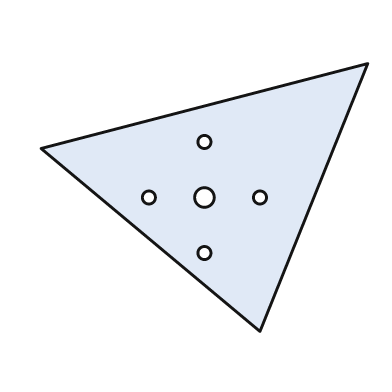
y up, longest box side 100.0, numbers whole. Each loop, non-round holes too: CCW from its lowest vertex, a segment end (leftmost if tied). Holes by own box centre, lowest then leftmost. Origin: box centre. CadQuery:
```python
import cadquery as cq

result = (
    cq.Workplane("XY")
    .moveTo(17.0, -41.0)
    .lineTo(50.0, 41.0)
    .lineTo(-50.0, 15.0)
    .close()
    .moveTo(0.0, -17.0)
    .circle(2.0)
    .moveTo(-17.0, 0.0)
    .circle(2.0)
    .moveTo(0.0, 0.0)
    .circle(3.0)
    .moveTo(17.0, 0.0)
    .circle(2.0)
    .moveTo(0.0, 17.0)
    .circle(2.0)
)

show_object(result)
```